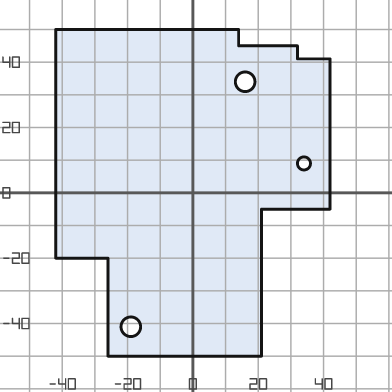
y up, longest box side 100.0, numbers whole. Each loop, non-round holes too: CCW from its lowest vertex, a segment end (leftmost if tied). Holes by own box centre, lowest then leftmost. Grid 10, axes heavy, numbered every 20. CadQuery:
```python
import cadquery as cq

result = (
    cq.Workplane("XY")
    .moveTo(-26.0, -50.0)
    .lineTo(21.0, -50.0)
    .lineTo(21.0, -5.0)
    .lineTo(42.0, -5.0)
    .lineTo(42.0, 41.0)
    .lineTo(32.0, 41.0)
    .lineTo(32.0, 45.0)
    .lineTo(14.0, 45.0)
    .lineTo(14.0, 50.0)
    .lineTo(-42.0, 50.0)
    .lineTo(-42.0, -20.0)
    .lineTo(-26.0, -20.0)
    .close()
    .moveTo(-19.0, -41.0)
    .circle(3.0)
    .moveTo(34.0, 9.0)
    .circle(2.0)
    .moveTo(16.0, 34.0)
    .circle(3.0)
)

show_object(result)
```